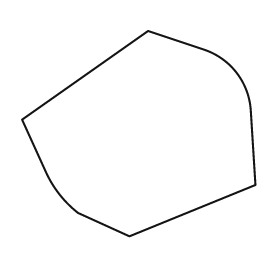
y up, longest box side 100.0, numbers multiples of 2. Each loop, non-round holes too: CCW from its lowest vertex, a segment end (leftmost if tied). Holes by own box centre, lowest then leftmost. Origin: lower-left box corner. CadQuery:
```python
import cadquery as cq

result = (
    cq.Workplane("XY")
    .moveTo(46.0, 0.0)
    .lineTo(100.0, 22.0)
    .lineTo(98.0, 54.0)
    .threePointArc((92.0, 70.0), (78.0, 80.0))
    .lineTo(54.0, 88.0)
    .lineTo(0.0, 50.0)
    .lineTo(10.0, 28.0)
    .threePointArc((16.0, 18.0), (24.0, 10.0))
    .close()
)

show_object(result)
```